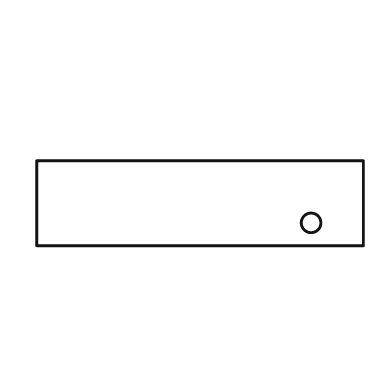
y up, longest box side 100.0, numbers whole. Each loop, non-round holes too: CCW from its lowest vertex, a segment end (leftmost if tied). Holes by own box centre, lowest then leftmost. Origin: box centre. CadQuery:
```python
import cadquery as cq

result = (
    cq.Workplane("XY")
    .moveTo(-50.0, -13.0)
    .lineTo(50.0, -13.0)
    .lineTo(50.0, 13.0)
    .lineTo(-50.0, 13.0)
    .close()
    .moveTo(34.0, -6.0)
    .circle(3.0)
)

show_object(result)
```